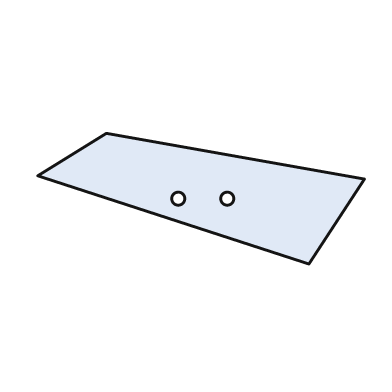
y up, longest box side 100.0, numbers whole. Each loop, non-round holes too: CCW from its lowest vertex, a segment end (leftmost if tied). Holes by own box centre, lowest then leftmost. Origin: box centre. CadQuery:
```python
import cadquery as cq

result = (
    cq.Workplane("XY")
    .moveTo(33.0, -20.0)
    .lineTo(50.0, 6.0)
    .lineTo(-29.0, 20.0)
    .lineTo(-50.0, 7.0)
    .close()
    .moveTo(-7.0, 0.0)
    .circle(2.0)
    .moveTo(8.0, 0.0)
    .circle(2.0)
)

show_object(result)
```